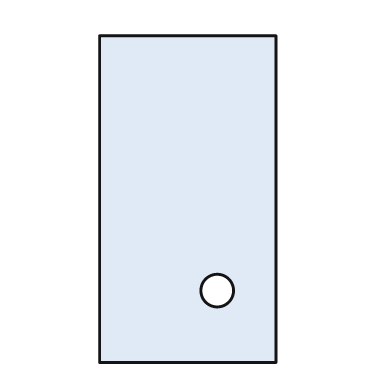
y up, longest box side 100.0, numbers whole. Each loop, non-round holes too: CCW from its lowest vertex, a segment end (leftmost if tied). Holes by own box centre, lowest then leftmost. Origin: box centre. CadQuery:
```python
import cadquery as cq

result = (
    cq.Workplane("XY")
    .moveTo(-27.0, -50.0)
    .lineTo(27.0, -50.0)
    .lineTo(27.0, 50.0)
    .lineTo(-27.0, 50.0)
    .close()
    .moveTo(9.0, -28.0)
    .circle(5.0)
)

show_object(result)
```